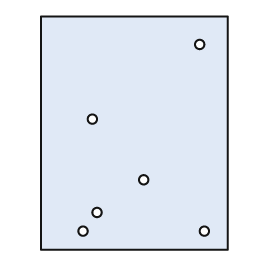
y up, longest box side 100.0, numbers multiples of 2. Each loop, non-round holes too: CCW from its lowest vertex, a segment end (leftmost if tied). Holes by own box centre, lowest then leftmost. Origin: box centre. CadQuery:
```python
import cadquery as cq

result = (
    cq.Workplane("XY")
    .moveTo(-40.0, -50.0)
    .lineTo(40.0, -50.0)
    .lineTo(40.0, 50.0)
    .lineTo(-40.0, 50.0)
    .close()
    .moveTo(-22.0, -42.0)
    .circle(2.0)
    .moveTo(30.0, -42.0)
    .circle(2.0)
    .moveTo(-16.0, -34.0)
    .circle(2.0)
    .moveTo(4.0, -20.0)
    .circle(2.0)
    .moveTo(-18.0, 6.0)
    .circle(2.0)
    .moveTo(28.0, 38.0)
    .circle(2.0)
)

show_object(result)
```